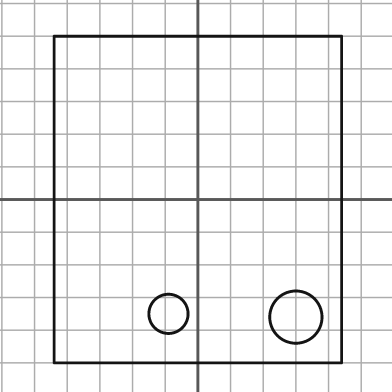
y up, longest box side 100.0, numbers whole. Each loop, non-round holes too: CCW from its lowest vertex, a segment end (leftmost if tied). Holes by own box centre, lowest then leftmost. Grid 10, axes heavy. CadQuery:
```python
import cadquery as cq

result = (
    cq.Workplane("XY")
    .moveTo(-44.0, -50.0)
    .lineTo(44.0, -50.0)
    .lineTo(44.0, 50.0)
    .lineTo(-44.0, 50.0)
    .close()
    .moveTo(30.0, -36.0)
    .circle(8.0)
    .moveTo(-9.0, -35.0)
    .circle(6.0)
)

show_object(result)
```